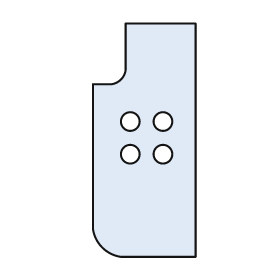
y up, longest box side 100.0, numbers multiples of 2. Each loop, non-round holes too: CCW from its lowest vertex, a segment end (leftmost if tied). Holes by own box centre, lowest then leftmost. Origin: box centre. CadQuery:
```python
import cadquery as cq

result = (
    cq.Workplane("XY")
    .moveTo(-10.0, -50.0)
    .lineTo(22.0, -50.0)
    .lineTo(22.0, 50.0)
    .lineTo(-8.0, 50.0)
    .lineTo(-8.0, 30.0)
    .threePointArc((-10.0, 26.0), (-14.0, 24.0))
    .lineTo(-22.0, 24.0)
    .lineTo(-22.0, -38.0)
    .threePointArc((-18.0, -46.0), (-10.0, -50.0))
    .close()
    .moveTo(-6.0, -6.0)
    .circle(4.0)
    .moveTo(8.0, -6.0)
    .circle(4.0)
    .moveTo(-6.0, 8.0)
    .circle(4.0)
    .moveTo(8.0, 8.0)
    .circle(4.0)
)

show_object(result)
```